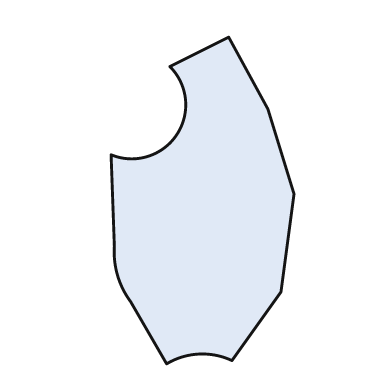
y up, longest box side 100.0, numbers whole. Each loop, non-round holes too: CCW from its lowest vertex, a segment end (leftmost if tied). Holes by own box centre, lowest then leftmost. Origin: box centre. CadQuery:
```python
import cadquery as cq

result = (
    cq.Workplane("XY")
    .moveTo(-11.0, -50.0)
    .threePointArc((-1.0, -47.0), (9.0, -49.0))
    .lineTo(24.0, -28.0)
    .lineTo(28.0, 2.0)
    .lineTo(20.0, 28.0)
    .lineTo(8.0, 50.0)
    .lineTo(-10.0, 41.0)
    .threePointArc((-8.0, 20.0), (-28.0, 14.0))
    .lineTo(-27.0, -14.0)
    .threePointArc((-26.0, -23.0), (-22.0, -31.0))
    .close()
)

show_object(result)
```